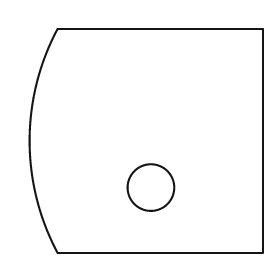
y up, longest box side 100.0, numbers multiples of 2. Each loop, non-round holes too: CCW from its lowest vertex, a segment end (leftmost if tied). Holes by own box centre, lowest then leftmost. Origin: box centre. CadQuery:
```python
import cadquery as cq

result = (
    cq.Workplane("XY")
    .moveTo(-38.0, -48.0)
    .lineTo(50.0, -48.0)
    .lineTo(50.0, 48.0)
    .lineTo(-38.0, 48.0)
    .threePointArc((-50.0, 0.0), (-38.0, -48.0))
    .close()
    .moveTo(2.0, -20.0)
    .circle(10.0)
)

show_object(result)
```